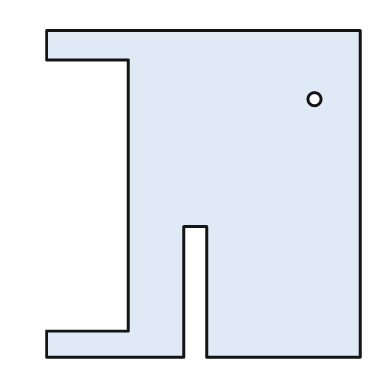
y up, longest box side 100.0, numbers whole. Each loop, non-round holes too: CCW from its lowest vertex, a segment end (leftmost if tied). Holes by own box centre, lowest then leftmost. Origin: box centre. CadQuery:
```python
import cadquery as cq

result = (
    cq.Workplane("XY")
    .moveTo(-48.0, -50.0)
    .lineTo(-6.0, -50.0)
    .lineTo(-6.0, -10.0)
    .lineTo(1.0, -10.0)
    .lineTo(1.0, -50.0)
    .lineTo(48.0, -50.0)
    .lineTo(48.0, 50.0)
    .lineTo(-48.0, 50.0)
    .lineTo(-48.0, 41.0)
    .lineTo(-23.0, 41.0)
    .lineTo(-23.0, -42.0)
    .lineTo(-48.0, -42.0)
    .close()
    .moveTo(34.0, 29.0)
    .circle(2.0)
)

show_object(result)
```